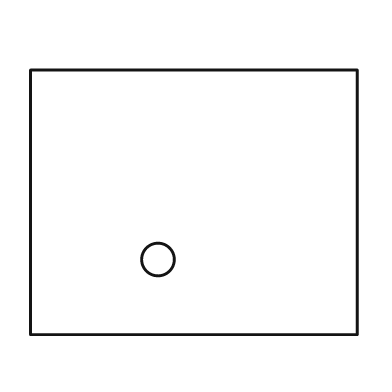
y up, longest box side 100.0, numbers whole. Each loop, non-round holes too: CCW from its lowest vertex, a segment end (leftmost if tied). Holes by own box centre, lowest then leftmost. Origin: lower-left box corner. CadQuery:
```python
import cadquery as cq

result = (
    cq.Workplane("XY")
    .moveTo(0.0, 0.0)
    .lineTo(100.0, 0.0)
    .lineTo(100.0, 81.0)
    .lineTo(0.0, 81.0)
    .close()
    .moveTo(39.0, 23.0)
    .circle(5.0)
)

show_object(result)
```